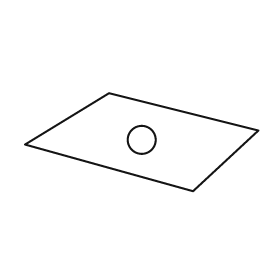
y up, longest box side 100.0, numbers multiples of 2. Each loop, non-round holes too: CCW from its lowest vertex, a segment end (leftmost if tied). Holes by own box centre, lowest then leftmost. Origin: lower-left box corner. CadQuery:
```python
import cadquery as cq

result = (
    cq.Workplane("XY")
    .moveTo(72.0, 0.0)
    .lineTo(100.0, 26.0)
    .lineTo(36.0, 42.0)
    .lineTo(0.0, 20.0)
    .close()
    .moveTo(50.0, 22.0)
    .circle(6.0)
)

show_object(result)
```